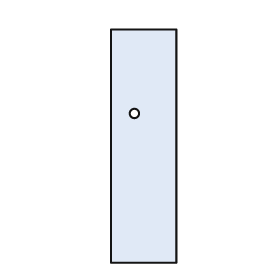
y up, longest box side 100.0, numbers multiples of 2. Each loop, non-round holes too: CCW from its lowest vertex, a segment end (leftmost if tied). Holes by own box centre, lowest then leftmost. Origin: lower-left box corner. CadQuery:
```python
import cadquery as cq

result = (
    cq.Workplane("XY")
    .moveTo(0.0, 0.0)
    .lineTo(28.0, 0.0)
    .lineTo(28.0, 100.0)
    .lineTo(0.0, 100.0)
    .close()
    .moveTo(10.0, 64.0)
    .circle(2.0)
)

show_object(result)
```